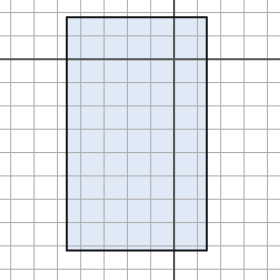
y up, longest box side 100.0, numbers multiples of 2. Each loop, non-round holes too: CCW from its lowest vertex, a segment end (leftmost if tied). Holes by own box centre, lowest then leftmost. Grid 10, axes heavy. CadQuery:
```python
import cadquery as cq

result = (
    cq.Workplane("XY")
    .moveTo(-46.0, -82.0)
    .lineTo(14.0, -82.0)
    .lineTo(14.0, 18.0)
    .lineTo(-46.0, 18.0)
    .close()
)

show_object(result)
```